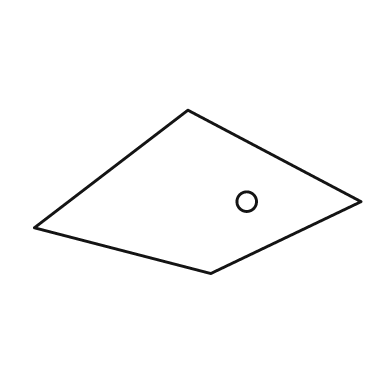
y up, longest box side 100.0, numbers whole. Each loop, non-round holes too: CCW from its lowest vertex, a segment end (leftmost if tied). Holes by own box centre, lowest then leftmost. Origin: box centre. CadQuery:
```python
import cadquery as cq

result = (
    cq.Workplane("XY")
    .moveTo(4.0, -25.0)
    .lineTo(50.0, -3.0)
    .lineTo(-3.0, 25.0)
    .lineTo(-50.0, -11.0)
    .close()
    .moveTo(15.0, -3.0)
    .circle(3.0)
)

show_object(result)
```